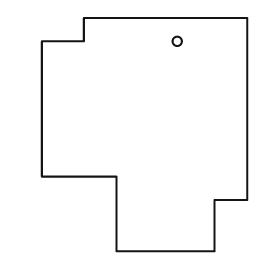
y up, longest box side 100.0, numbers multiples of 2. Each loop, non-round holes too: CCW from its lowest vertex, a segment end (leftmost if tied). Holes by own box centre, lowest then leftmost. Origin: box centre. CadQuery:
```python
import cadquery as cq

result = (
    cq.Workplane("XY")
    .moveTo(-12.0, -50.0)
    .lineTo(30.0, -50.0)
    .lineTo(30.0, -28.0)
    .lineTo(44.0, -28.0)
    .lineTo(44.0, 50.0)
    .lineTo(-26.0, 50.0)
    .lineTo(-26.0, 40.0)
    .lineTo(-44.0, 40.0)
    .lineTo(-44.0, -18.0)
    .lineTo(-12.0, -18.0)
    .close()
    .moveTo(14.0, 40.0)
    .circle(2.0)
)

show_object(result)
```